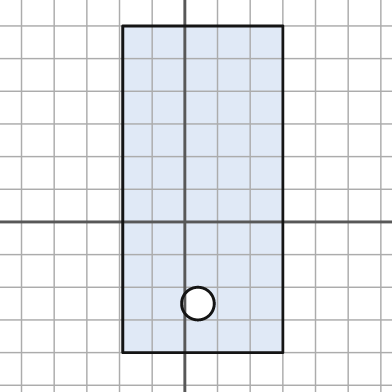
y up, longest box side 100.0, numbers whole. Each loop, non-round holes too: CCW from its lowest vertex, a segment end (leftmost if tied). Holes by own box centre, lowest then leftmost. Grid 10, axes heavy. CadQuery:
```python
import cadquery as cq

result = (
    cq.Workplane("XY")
    .moveTo(-19.0, -40.0)
    .lineTo(30.0, -40.0)
    .lineTo(30.0, 60.0)
    .lineTo(-19.0, 60.0)
    .close()
    .moveTo(4.0, -25.0)
    .circle(5.0)
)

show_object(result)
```